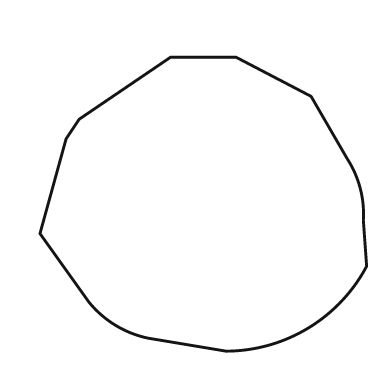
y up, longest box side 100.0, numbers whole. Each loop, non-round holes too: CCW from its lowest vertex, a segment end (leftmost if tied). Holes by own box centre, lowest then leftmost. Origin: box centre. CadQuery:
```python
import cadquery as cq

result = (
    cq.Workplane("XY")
    .moveTo(7.0, -45.0)
    .threePointArc((32.0, -38.0), (50.0, -19.0))
    .lineTo(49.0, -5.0)
    .threePointArc((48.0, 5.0), (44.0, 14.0))
    .lineTo(33.0, 33.0)
    .lineTo(10.0, 45.0)
    .lineTo(-10.0, 45.0)
    .lineTo(-38.0, 26.0)
    .lineTo(-42.0, 20.0)
    .lineTo(-50.0, -9.0)
    .lineTo(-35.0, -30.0)
    .threePointArc((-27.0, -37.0), (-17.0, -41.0))
    .close()
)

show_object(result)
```